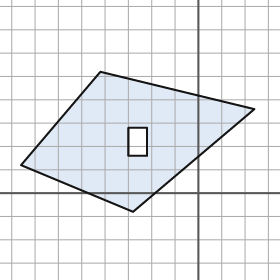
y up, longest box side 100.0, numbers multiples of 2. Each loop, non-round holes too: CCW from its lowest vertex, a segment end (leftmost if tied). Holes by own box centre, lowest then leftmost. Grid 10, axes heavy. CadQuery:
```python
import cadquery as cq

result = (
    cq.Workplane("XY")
    .moveTo(-28.0, -8.0)
    .lineTo(24.0, 36.0)
    .lineTo(-42.0, 52.0)
    .lineTo(-76.0, 12.0)
    .close()
    .moveTo(-30.0, 16.0)
    .lineTo(-22.0, 16.0)
    .lineTo(-22.0, 28.0)
    .lineTo(-30.0, 28.0)
    .close()
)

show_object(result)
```